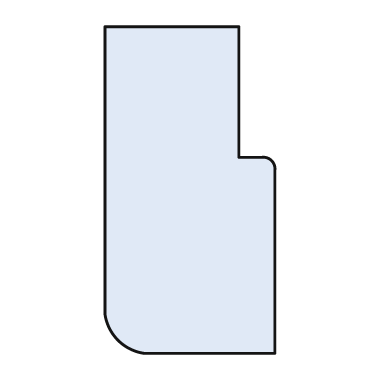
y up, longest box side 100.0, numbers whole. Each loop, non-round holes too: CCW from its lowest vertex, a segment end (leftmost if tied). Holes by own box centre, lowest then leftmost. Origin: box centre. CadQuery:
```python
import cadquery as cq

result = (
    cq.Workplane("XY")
    .moveTo(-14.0, -50.0)
    .lineTo(26.0, -50.0)
    .lineTo(26.0, 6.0)
    .threePointArc((25.0, 9.0), (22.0, 10.0))
    .lineTo(15.0, 10.0)
    .lineTo(15.0, 50.0)
    .lineTo(-26.0, 50.0)
    .lineTo(-26.0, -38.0)
    .threePointArc((-22.0, -46.0), (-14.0, -50.0))
    .close()
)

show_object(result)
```